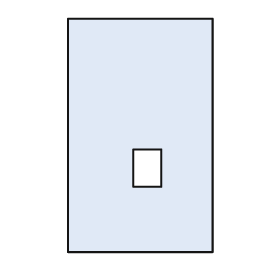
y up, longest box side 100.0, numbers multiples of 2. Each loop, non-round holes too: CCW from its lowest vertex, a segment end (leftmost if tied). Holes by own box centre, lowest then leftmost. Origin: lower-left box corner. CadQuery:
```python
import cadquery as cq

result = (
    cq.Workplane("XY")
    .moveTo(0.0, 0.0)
    .lineTo(62.0, 0.0)
    .lineTo(62.0, 100.0)
    .lineTo(0.0, 100.0)
    .close()
    .moveTo(28.0, 28.0)
    .lineTo(40.0, 28.0)
    .lineTo(40.0, 44.0)
    .lineTo(28.0, 44.0)
    .close()
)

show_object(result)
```